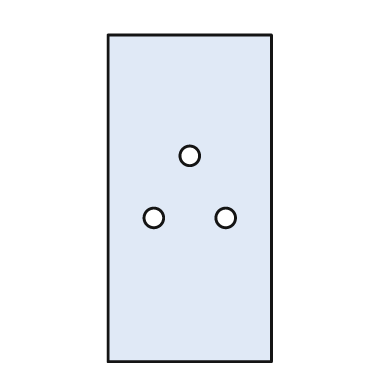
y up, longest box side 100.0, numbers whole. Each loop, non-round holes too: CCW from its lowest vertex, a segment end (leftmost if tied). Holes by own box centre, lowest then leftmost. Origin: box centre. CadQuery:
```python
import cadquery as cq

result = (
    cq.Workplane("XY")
    .moveTo(-25.0, -50.0)
    .lineTo(25.0, -50.0)
    .lineTo(25.0, 50.0)
    .lineTo(-25.0, 50.0)
    .close()
    .moveTo(-11.0, -6.0)
    .circle(3.0)
    .moveTo(11.0, -6.0)
    .circle(3.0)
    .moveTo(0.0, 13.0)
    .circle(3.0)
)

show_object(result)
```